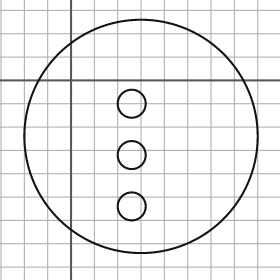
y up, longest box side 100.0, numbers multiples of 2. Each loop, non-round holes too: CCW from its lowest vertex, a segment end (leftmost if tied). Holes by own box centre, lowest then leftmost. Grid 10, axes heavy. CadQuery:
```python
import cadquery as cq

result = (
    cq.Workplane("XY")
    .moveTo(30.0, -24.0)
    .circle(50.0)
    .moveTo(26.0, -54.0)
    .circle(6.0)
    .moveTo(26.0, -32.0)
    .circle(6.0)
    .moveTo(26.0, -10.0)
    .circle(6.0)
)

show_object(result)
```